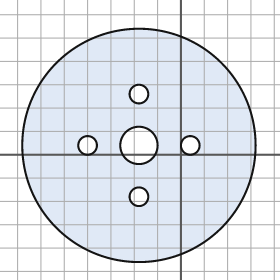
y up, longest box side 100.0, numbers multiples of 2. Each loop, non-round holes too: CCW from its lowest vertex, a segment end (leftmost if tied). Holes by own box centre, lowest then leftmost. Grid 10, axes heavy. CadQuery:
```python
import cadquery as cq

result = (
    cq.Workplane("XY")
    .moveTo(-18.0, 4.0)
    .circle(50.0)
    .moveTo(-18.0, -18.0)
    .circle(4.0)
    .moveTo(-40.0, 4.0)
    .circle(4.0)
    .moveTo(-18.0, 4.0)
    .circle(8.0)
    .moveTo(4.0, 4.0)
    .circle(4.0)
    .moveTo(-18.0, 26.0)
    .circle(4.0)
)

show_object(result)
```